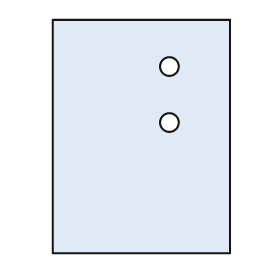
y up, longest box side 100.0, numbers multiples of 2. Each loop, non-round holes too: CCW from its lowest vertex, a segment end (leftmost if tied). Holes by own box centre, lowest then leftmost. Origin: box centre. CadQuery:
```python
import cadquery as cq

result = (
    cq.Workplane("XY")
    .moveTo(-38.0, -50.0)
    .lineTo(38.0, -50.0)
    .lineTo(38.0, 50.0)
    .lineTo(-38.0, 50.0)
    .close()
    .moveTo(12.0, 6.0)
    .circle(4.0)
    .moveTo(12.0, 30.0)
    .circle(4.0)
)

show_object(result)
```